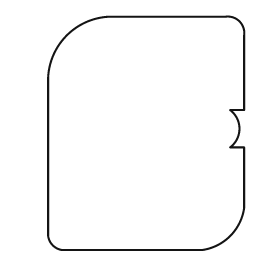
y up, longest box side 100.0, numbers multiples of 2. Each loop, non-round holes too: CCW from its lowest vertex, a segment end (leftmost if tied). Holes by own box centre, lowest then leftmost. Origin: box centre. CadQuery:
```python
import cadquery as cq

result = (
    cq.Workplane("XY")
    .moveTo(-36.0, -50.0)
    .lineTo(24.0, -50.0)
    .threePointArc((36.0, -44.0), (42.0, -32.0))
    .lineTo(42.0, -6.0)
    .lineTo(36.0, -6.0)
    .threePointArc((40.0, 2.0), (36.0, 10.0))
    .lineTo(42.0, 10.0)
    .lineTo(42.0, 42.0)
    .threePointArc((40.0, 48.0), (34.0, 50.0))
    .lineTo(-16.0, 50.0)
    .threePointArc((-34.0, 42.0), (-42.0, 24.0))
    .lineTo(-42.0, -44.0)
    .threePointArc((-40.0, -48.0), (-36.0, -50.0))
    .close()
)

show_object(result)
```